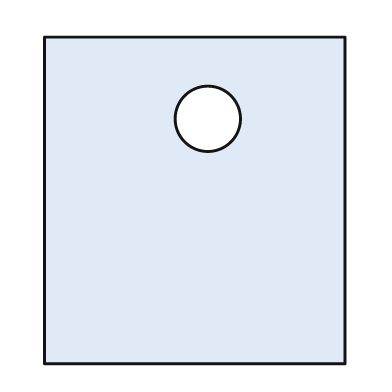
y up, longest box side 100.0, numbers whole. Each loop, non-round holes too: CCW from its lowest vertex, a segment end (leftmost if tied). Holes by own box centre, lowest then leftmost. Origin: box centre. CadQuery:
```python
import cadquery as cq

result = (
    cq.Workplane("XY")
    .moveTo(-46.0, -50.0)
    .lineTo(46.0, -50.0)
    .lineTo(46.0, 50.0)
    .lineTo(-46.0, 50.0)
    .close()
    .moveTo(4.0, 25.0)
    .circle(10.0)
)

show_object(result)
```